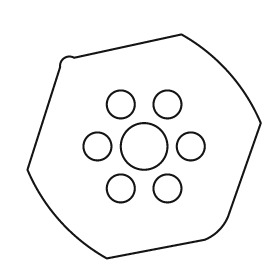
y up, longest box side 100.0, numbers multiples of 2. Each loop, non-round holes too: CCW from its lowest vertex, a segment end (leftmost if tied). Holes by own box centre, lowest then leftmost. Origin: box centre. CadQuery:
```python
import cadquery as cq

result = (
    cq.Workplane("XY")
    .moveTo(-16.0, -48.0)
    .lineTo(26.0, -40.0)
    .threePointArc((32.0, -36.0), (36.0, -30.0))
    .lineTo(50.0, 10.0)
    .threePointArc((36.0, 32.0), (16.0, 48.0))
    .lineTo(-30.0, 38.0)
    .threePointArc((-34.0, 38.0), (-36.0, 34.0))
    .lineTo(-50.0, -10.0)
    .threePointArc((-36.0, -32.0), (-16.0, -48.0))
    .close()
    .moveTo(-10.0, -18.0)
    .circle(6.0)
    .moveTo(10.0, -18.0)
    .circle(6.0)
    .moveTo(-20.0, 0.0)
    .circle(6.0)
    .moveTo(0.0, 0.0)
    .circle(10.0)
    .moveTo(20.0, 0.0)
    .circle(6.0)
    .moveTo(-10.0, 18.0)
    .circle(6.0)
    .moveTo(10.0, 18.0)
    .circle(6.0)
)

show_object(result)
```